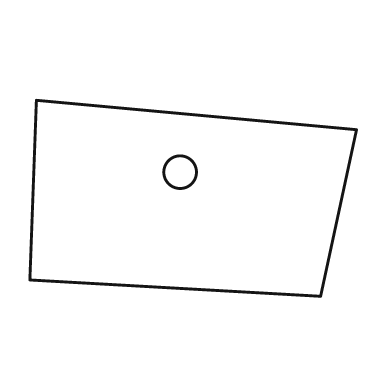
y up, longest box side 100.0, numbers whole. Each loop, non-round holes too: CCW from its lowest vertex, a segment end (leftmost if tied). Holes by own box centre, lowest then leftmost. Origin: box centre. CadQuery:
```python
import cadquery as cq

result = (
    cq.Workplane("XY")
    .moveTo(39.0, -30.0)
    .lineTo(50.0, 21.0)
    .lineTo(-48.0, 30.0)
    .lineTo(-50.0, -25.0)
    .close()
    .moveTo(-4.0, 8.0)
    .circle(5.0)
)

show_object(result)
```